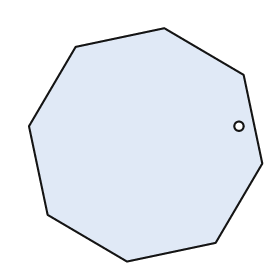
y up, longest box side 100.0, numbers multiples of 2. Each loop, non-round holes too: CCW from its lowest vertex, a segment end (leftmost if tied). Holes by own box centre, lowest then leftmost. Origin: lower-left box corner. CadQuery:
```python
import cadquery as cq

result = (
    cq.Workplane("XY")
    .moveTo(42.0, 0.0)
    .lineTo(80.0, 8.0)
    .lineTo(100.0, 42.0)
    .lineTo(92.0, 80.0)
    .lineTo(58.0, 100.0)
    .lineTo(20.0, 92.0)
    .lineTo(0.0, 58.0)
    .lineTo(8.0, 20.0)
    .close()
    .moveTo(90.0, 58.0)
    .circle(2.0)
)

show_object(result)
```